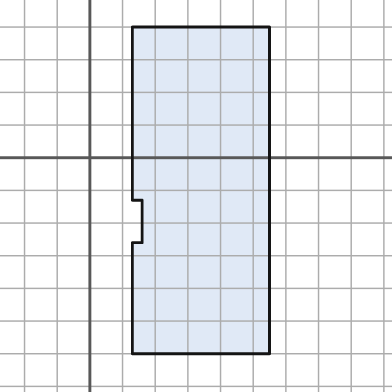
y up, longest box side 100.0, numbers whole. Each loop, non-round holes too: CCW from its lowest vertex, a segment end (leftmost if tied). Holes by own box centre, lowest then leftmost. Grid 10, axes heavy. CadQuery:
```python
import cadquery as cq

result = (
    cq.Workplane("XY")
    .moveTo(13.0, -60.0)
    .lineTo(55.0, -60.0)
    .lineTo(55.0, 40.0)
    .lineTo(13.0, 40.0)
    .lineTo(13.0, -13.0)
    .lineTo(16.0, -13.0)
    .lineTo(16.0, -26.0)
    .lineTo(13.0, -26.0)
    .close()
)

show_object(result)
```